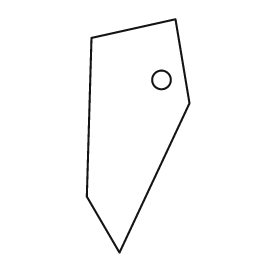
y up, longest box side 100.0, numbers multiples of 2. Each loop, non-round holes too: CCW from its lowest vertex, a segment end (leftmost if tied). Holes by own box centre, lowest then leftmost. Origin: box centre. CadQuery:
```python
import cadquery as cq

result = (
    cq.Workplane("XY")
    .moveTo(-8.0, -50.0)
    .lineTo(22.0, 14.0)
    .lineTo(16.0, 50.0)
    .lineTo(-20.0, 42.0)
    .lineTo(-22.0, -26.0)
    .close()
    .moveTo(10.0, 24.0)
    .circle(4.0)
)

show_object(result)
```